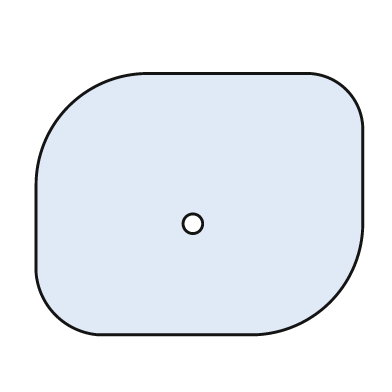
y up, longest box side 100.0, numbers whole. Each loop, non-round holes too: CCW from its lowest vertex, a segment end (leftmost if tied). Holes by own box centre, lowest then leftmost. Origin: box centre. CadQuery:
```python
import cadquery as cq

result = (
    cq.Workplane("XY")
    .moveTo(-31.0, -40.0)
    .lineTo(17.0, -40.0)
    .threePointArc((40.0, -30.0), (50.0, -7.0))
    .lineTo(50.0, 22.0)
    .threePointArc((45.0, 35.0), (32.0, 40.0))
    .lineTo(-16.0, 40.0)
    .threePointArc((-40.0, 30.0), (-50.0, 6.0))
    .lineTo(-50.0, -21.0)
    .threePointArc((-44.0, -34.0), (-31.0, -40.0))
    .close()
    .moveTo(-2.0, -6.0)
    .circle(3.0)
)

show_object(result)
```